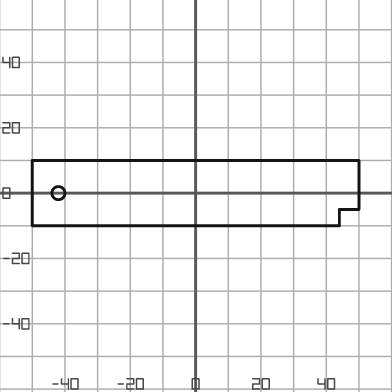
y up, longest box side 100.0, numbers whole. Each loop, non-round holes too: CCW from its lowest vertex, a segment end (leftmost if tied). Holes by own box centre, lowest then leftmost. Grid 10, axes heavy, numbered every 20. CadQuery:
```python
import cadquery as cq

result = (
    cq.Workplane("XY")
    .moveTo(-50.0, -10.0)
    .lineTo(44.0, -10.0)
    .lineTo(44.0, -5.0)
    .lineTo(50.0, -5.0)
    .lineTo(50.0, 10.0)
    .lineTo(-50.0, 10.0)
    .close()
    .moveTo(-42.0, 0.0)
    .circle(2.0)
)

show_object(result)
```